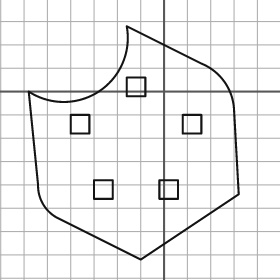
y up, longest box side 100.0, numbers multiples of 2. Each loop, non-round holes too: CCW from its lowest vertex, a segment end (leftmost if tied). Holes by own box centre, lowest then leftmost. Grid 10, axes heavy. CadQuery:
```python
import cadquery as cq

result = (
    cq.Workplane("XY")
    .moveTo(-10.0, -72.0)
    .lineTo(32.0, -44.0)
    .lineTo(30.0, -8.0)
    .threePointArc((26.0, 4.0), (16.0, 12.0))
    .lineTo(-16.0, 28.0)
    .threePointArc((-28.0, 0.0), (-58.0, 0.0))
    .lineTo(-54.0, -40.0)
    .threePointArc((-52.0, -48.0), (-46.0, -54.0))
    .close()
    .moveTo(-30.0, -46.0)
    .lineTo(-22.0, -46.0)
    .lineTo(-22.0, -38.0)
    .lineTo(-30.0, -38.0)
    .close()
    .moveTo(-2.0, -46.0)
    .lineTo(6.0, -46.0)
    .lineTo(6.0, -38.0)
    .lineTo(-2.0, -38.0)
    .close()
    .moveTo(-40.0, -18.0)
    .lineTo(-32.0, -18.0)
    .lineTo(-32.0, -10.0)
    .lineTo(-40.0, -10.0)
    .close()
    .moveTo(8.0, -18.0)
    .lineTo(16.0, -18.0)
    .lineTo(16.0, -10.0)
    .lineTo(8.0, -10.0)
    .close()
    .moveTo(-16.0, -2.0)
    .lineTo(-8.0, -2.0)
    .lineTo(-8.0, 6.0)
    .lineTo(-16.0, 6.0)
    .close()
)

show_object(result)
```